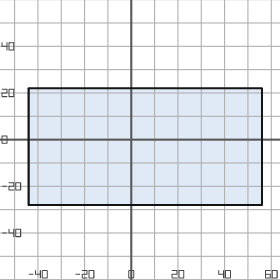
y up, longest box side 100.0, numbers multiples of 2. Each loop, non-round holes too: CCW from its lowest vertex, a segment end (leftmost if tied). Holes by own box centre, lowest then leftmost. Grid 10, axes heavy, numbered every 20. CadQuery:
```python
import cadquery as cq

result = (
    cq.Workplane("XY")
    .moveTo(-44.0, -28.0)
    .lineTo(56.0, -28.0)
    .lineTo(56.0, 22.0)
    .lineTo(-44.0, 22.0)
    .close()
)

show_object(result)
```